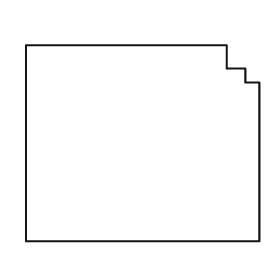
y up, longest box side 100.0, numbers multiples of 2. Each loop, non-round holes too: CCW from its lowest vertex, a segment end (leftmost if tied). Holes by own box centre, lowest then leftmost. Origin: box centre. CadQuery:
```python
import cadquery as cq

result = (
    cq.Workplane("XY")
    .moveTo(-50.0, -42.0)
    .lineTo(50.0, -42.0)
    .lineTo(50.0, 26.0)
    .lineTo(44.0, 26.0)
    .lineTo(44.0, 32.0)
    .lineTo(36.0, 32.0)
    .lineTo(36.0, 42.0)
    .lineTo(-50.0, 42.0)
    .close()
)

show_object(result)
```